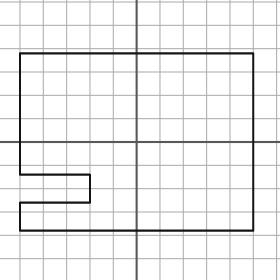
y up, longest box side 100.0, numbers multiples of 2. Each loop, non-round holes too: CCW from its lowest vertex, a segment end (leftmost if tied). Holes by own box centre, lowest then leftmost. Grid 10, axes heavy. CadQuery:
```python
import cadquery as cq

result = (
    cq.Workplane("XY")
    .moveTo(-50.0, -38.0)
    .lineTo(50.0, -38.0)
    .lineTo(50.0, 38.0)
    .lineTo(-50.0, 38.0)
    .lineTo(-50.0, -14.0)
    .lineTo(-20.0, -14.0)
    .lineTo(-20.0, -26.0)
    .lineTo(-50.0, -26.0)
    .close()
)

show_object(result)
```